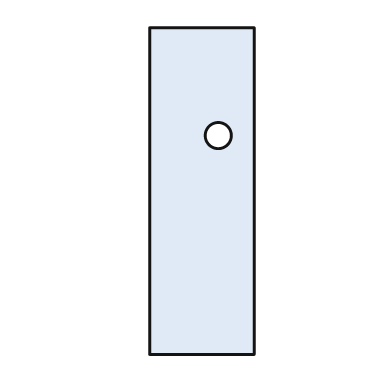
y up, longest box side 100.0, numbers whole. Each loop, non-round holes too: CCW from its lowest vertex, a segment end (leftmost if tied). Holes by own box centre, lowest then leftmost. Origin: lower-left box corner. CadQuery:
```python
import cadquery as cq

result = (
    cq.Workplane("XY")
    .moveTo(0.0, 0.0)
    .lineTo(32.0, 0.0)
    .lineTo(32.0, 100.0)
    .lineTo(0.0, 100.0)
    .close()
    .moveTo(21.0, 67.0)
    .circle(4.0)
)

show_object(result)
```